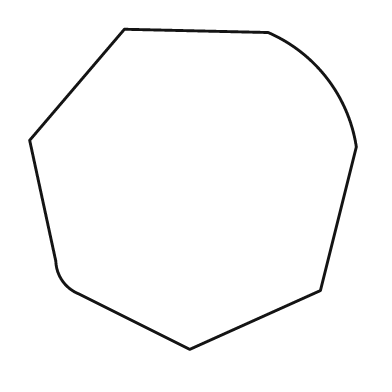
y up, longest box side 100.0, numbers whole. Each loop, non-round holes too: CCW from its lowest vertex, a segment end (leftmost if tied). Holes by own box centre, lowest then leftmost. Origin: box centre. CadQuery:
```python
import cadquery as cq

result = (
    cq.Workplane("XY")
    .moveTo(-1.0, -49.0)
    .lineTo(39.0, -31.0)
    .lineTo(50.0, 13.0)
    .threePointArc((41.0, 34.0), (23.0, 48.0))
    .lineTo(-21.0, 49.0)
    .lineTo(-50.0, 15.0)
    .lineTo(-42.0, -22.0)
    .threePointArc((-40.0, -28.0), (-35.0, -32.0))
    .close()
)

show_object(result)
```